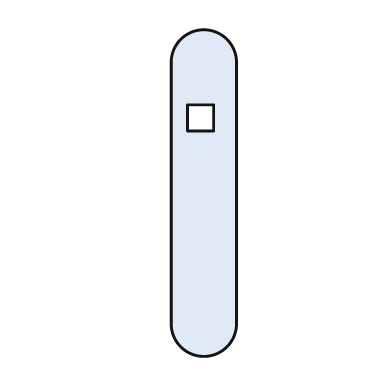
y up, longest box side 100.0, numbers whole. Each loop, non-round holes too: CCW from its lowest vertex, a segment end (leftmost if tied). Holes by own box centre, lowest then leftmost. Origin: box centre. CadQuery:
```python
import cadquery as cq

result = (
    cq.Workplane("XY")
    .moveTo(-10.0, -40.0)
    .threePointArc((0.0, -50.0), (10.0, -40.0))
    .lineTo(10.0, 40.0)
    .threePointArc((0.0, 50.0), (-10.0, 40.0))
    .close()
    .moveTo(-5.0, 19.0)
    .lineTo(3.0, 19.0)
    .lineTo(3.0, 27.0)
    .lineTo(-5.0, 27.0)
    .close()
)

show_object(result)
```